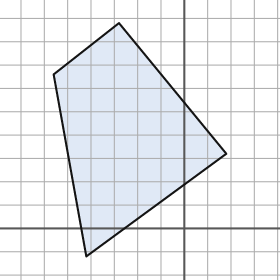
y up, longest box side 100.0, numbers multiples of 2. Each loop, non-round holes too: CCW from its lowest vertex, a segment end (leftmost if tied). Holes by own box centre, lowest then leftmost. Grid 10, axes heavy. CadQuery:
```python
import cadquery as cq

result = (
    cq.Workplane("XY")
    .moveTo(-42.0, -12.0)
    .lineTo(18.0, 32.0)
    .lineTo(-28.0, 88.0)
    .lineTo(-56.0, 66.0)
    .close()
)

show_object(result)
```